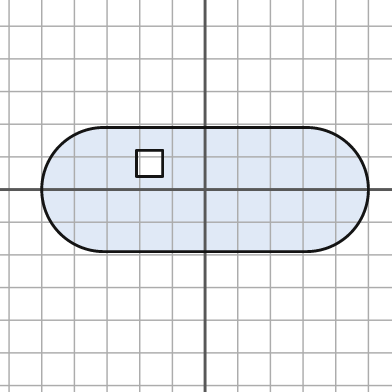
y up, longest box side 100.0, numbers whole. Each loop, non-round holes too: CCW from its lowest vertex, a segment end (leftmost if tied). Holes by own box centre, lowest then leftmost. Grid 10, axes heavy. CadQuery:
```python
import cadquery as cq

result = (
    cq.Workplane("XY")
    .moveTo(-31.0, -19.0)
    .lineTo(31.0, -19.0)
    .threePointArc((50.0, 0.0), (31.0, 19.0))
    .lineTo(-31.0, 19.0)
    .threePointArc((-50.0, 0.0), (-31.0, -19.0))
    .close()
    .moveTo(-21.0, 4.0)
    .lineTo(-13.0, 4.0)
    .lineTo(-13.0, 12.0)
    .lineTo(-21.0, 12.0)
    .close()
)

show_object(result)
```